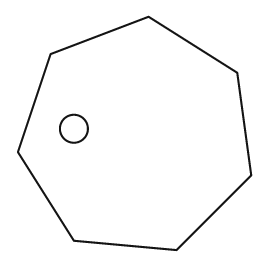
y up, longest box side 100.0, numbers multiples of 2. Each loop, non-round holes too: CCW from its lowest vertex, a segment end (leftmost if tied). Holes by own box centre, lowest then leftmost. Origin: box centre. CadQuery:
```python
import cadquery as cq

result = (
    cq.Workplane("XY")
    .moveTo(18.0, -50.0)
    .lineTo(50.0, -18.0)
    .lineTo(44.0, 26.0)
    .lineTo(6.0, 50.0)
    .lineTo(-36.0, 34.0)
    .lineTo(-50.0, -8.0)
    .lineTo(-26.0, -46.0)
    .close()
    .moveTo(-26.0, 2.0)
    .circle(6.0)
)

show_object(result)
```